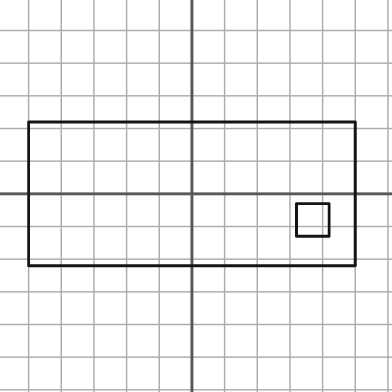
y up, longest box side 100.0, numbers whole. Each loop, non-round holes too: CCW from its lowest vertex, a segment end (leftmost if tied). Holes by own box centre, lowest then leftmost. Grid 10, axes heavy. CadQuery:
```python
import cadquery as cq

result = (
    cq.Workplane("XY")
    .moveTo(-50.0, -22.0)
    .lineTo(50.0, -22.0)
    .lineTo(50.0, 22.0)
    .lineTo(-50.0, 22.0)
    .close()
    .moveTo(32.0, -13.0)
    .lineTo(42.0, -13.0)
    .lineTo(42.0, -3.0)
    .lineTo(32.0, -3.0)
    .close()
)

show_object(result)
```